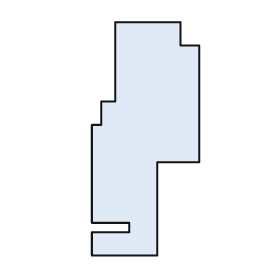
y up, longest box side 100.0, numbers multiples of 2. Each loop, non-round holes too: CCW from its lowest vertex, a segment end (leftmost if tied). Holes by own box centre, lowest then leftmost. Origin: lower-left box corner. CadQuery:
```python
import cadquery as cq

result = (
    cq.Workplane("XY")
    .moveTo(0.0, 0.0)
    .lineTo(28.0, 0.0)
    .lineTo(28.0, 40.0)
    .lineTo(46.0, 40.0)
    .lineTo(46.0, 90.0)
    .lineTo(38.0, 90.0)
    .lineTo(38.0, 100.0)
    .lineTo(10.0, 100.0)
    .lineTo(10.0, 66.0)
    .lineTo(4.0, 66.0)
    .lineTo(4.0, 56.0)
    .lineTo(0.0, 56.0)
    .lineTo(0.0, 14.0)
    .lineTo(16.0, 14.0)
    .lineTo(16.0, 10.0)
    .lineTo(0.0, 10.0)
    .close()
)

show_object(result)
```